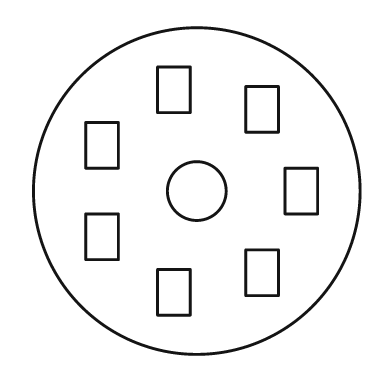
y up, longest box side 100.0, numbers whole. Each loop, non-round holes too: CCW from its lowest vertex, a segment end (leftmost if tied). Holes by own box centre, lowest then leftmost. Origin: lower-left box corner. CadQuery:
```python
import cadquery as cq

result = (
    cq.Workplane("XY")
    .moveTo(50.0, 50.0)
    .circle(50.0)
    .moveTo(38.0, 12.0)
    .lineTo(48.0, 12.0)
    .lineTo(48.0, 26.0)
    .lineTo(38.0, 26.0)
    .close()
    .moveTo(65.0, 18.0)
    .lineTo(75.0, 18.0)
    .lineTo(75.0, 32.0)
    .lineTo(65.0, 32.0)
    .close()
    .moveTo(16.0, 29.0)
    .lineTo(26.0, 29.0)
    .lineTo(26.0, 43.0)
    .lineTo(16.0, 43.0)
    .close()
    .moveTo(50.0, 50.0)
    .circle(9.0)
    .moveTo(77.0, 43.0)
    .lineTo(87.0, 43.0)
    .lineTo(87.0, 57.0)
    .lineTo(77.0, 57.0)
    .close()
    .moveTo(16.0, 57.0)
    .lineTo(26.0, 57.0)
    .lineTo(26.0, 71.0)
    .lineTo(16.0, 71.0)
    .close()
    .moveTo(65.0, 68.0)
    .lineTo(75.0, 68.0)
    .lineTo(75.0, 82.0)
    .lineTo(65.0, 82.0)
    .close()
    .moveTo(38.0, 74.0)
    .lineTo(48.0, 74.0)
    .lineTo(48.0, 88.0)
    .lineTo(38.0, 88.0)
    .close()
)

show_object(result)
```